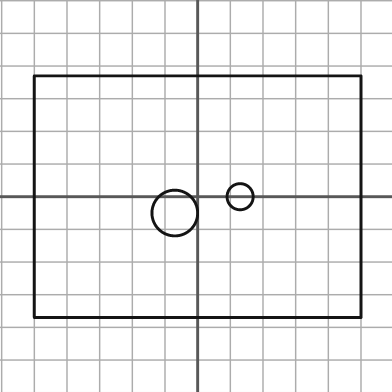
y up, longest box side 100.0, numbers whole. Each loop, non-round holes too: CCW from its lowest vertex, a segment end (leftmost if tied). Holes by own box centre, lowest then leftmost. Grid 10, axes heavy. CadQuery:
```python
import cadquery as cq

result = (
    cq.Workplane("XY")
    .moveTo(-50.0, -37.0)
    .lineTo(50.0, -37.0)
    .lineTo(50.0, 37.0)
    .lineTo(-50.0, 37.0)
    .close()
    .moveTo(-7.0, -5.0)
    .circle(7.0)
    .moveTo(13.0, 0.0)
    .circle(4.0)
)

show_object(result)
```